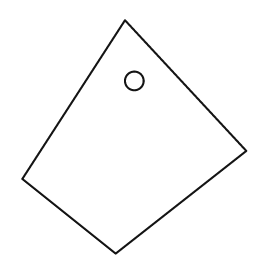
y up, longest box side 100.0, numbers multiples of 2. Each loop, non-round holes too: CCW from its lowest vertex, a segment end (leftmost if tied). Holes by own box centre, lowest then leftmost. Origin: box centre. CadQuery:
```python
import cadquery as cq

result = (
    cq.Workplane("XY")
    .moveTo(-8.0, -50.0)
    .lineTo(48.0, -6.0)
    .lineTo(-4.0, 50.0)
    .lineTo(-48.0, -18.0)
    .close()
    .moveTo(0.0, 24.0)
    .circle(4.0)
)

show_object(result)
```